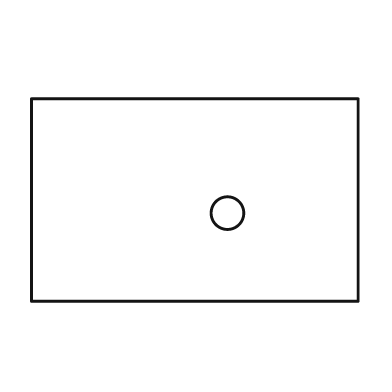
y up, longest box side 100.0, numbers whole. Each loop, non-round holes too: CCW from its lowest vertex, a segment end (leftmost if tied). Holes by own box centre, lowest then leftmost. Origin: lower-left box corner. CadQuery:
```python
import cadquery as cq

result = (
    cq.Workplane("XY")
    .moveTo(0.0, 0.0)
    .lineTo(100.0, 0.0)
    .lineTo(100.0, 62.0)
    .lineTo(0.0, 62.0)
    .close()
    .moveTo(60.0, 27.0)
    .circle(5.0)
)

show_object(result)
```